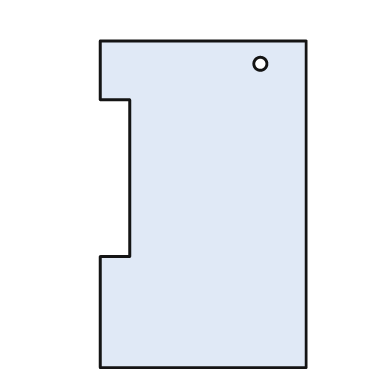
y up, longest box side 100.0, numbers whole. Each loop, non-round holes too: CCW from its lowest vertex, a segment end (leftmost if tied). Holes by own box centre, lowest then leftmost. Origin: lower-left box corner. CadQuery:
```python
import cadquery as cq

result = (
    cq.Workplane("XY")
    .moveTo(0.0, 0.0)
    .lineTo(63.0, 0.0)
    .lineTo(63.0, 100.0)
    .lineTo(0.0, 100.0)
    .lineTo(0.0, 82.0)
    .lineTo(9.0, 82.0)
    .lineTo(9.0, 34.0)
    .lineTo(0.0, 34.0)
    .close()
    .moveTo(49.0, 93.0)
    .circle(2.0)
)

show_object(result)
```